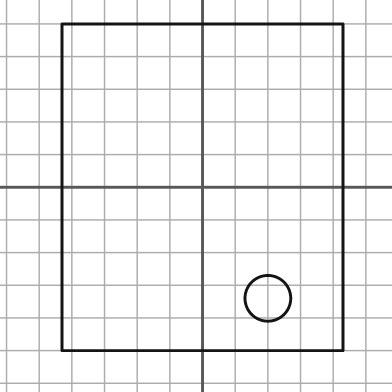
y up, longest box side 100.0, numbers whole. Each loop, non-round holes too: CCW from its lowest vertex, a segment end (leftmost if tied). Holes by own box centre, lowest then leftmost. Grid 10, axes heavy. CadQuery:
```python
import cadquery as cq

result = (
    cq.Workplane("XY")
    .moveTo(-43.0, -50.0)
    .lineTo(43.0, -50.0)
    .lineTo(43.0, 50.0)
    .lineTo(-43.0, 50.0)
    .close()
    .moveTo(20.0, -34.0)
    .circle(7.0)
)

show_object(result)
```